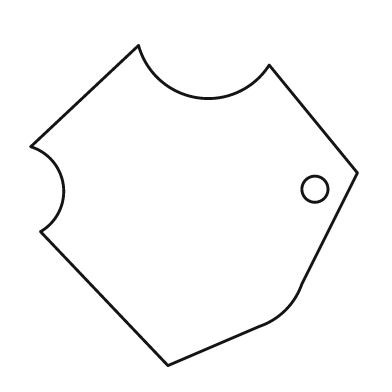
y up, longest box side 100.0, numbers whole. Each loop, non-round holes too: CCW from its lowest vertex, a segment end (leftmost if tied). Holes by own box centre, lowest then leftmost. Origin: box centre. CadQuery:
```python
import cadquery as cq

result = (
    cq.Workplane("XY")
    .moveTo(-8.0, -49.0)
    .lineTo(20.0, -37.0)
    .threePointArc((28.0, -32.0), (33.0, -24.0))
    .lineTo(50.0, 10.0)
    .lineTo(23.0, 43.0)
    .threePointArc((1.0, 33.0), (-17.0, 49.0))
    .lineTo(-50.0, 18.0)
    .threePointArc((-40.0, 6.0), (-47.0, -8.0))
    .close()
    .moveTo(37.0, 5.0)
    .circle(4.0)
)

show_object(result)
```